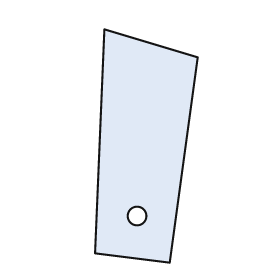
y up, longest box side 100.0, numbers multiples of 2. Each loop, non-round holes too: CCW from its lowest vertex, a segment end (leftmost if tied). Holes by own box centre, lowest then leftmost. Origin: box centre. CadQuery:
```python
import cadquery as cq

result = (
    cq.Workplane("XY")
    .moveTo(10.0, -50.0)
    .lineTo(22.0, 38.0)
    .lineTo(-18.0, 50.0)
    .lineTo(-22.0, -46.0)
    .close()
    .moveTo(-4.0, -30.0)
    .circle(4.0)
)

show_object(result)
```